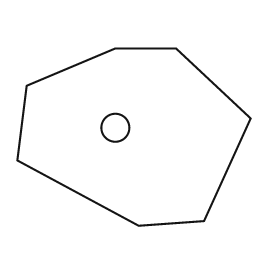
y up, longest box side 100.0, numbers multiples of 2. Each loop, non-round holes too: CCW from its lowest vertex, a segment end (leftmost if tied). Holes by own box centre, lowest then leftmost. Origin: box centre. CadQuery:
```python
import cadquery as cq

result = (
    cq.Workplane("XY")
    .moveTo(2.0, -38.0)
    .lineTo(30.0, -36.0)
    .lineTo(50.0, 8.0)
    .lineTo(18.0, 38.0)
    .lineTo(-8.0, 38.0)
    .lineTo(-46.0, 22.0)
    .lineTo(-50.0, -10.0)
    .close()
    .moveTo(-8.0, 4.0)
    .circle(6.0)
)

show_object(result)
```